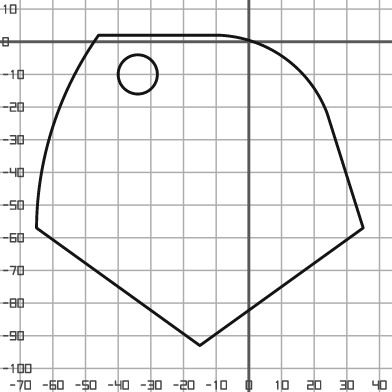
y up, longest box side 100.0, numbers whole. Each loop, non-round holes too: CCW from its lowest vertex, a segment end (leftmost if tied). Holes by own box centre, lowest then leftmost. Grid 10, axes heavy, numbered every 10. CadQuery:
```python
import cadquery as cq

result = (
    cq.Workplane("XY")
    .moveTo(-15.0, -93.0)
    .lineTo(35.0, -57.0)
    .lineTo(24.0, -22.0)
    .threePointArc((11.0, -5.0), (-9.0, 2.0))
    .lineTo(-46.0, 2.0)
    .threePointArc((-60.0, -26.0), (-65.0, -57.0))
    .close()
    .moveTo(-34.0, -10.0)
    .circle(6.0)
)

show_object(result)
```